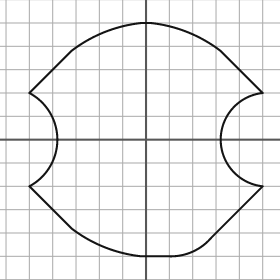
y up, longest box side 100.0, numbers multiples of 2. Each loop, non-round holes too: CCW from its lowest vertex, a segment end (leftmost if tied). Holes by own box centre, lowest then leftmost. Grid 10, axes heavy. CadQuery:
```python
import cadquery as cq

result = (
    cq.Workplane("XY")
    .moveTo(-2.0, -50.0)
    .lineTo(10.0, -50.0)
    .threePointArc((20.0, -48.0), (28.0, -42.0))
    .lineTo(50.0, -20.0)
    .threePointArc((32.0, 0.0), (50.0, 20.0))
    .lineTo(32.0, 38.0)
    .threePointArc((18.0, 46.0), (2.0, 50.0))
    .lineTo(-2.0, 50.0)
    .threePointArc((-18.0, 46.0), (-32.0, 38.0))
    .lineTo(-50.0, 20.0)
    .threePointArc((-38.0, 0.0), (-50.0, -20.0))
    .lineTo(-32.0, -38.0)
    .threePointArc((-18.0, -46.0), (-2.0, -50.0))
    .close()
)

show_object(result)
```